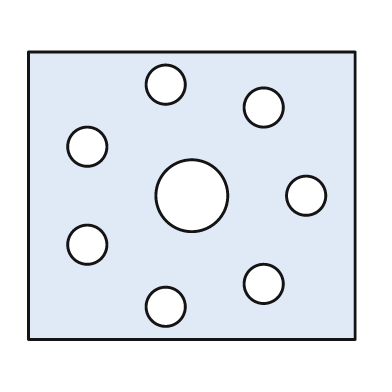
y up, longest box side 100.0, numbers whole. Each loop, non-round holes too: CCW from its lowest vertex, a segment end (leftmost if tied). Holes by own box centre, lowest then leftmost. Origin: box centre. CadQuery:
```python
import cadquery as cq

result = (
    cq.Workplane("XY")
    .moveTo(-50.0, -44.0)
    .lineTo(50.0, -44.0)
    .lineTo(50.0, 44.0)
    .lineTo(-50.0, 44.0)
    .close()
    .moveTo(-8.0, -34.0)
    .circle(6.0)
    .moveTo(22.0, -27.0)
    .circle(6.0)
    .moveTo(-32.0, -15.0)
    .circle(6.0)
    .moveTo(0.0, 0.0)
    .circle(11.0)
    .moveTo(35.0, 0.0)
    .circle(6.0)
    .moveTo(-32.0, 15.0)
    .circle(6.0)
    .moveTo(22.0, 27.0)
    .circle(6.0)
    .moveTo(-8.0, 34.0)
    .circle(6.0)
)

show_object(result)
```